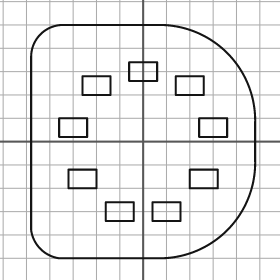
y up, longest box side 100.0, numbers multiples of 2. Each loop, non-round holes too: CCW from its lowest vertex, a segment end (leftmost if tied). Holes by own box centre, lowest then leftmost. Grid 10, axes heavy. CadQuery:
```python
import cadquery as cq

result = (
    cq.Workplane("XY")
    .moveTo(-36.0, -50.0)
    .lineTo(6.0, -50.0)
    .threePointArc((36.0, -38.0), (48.0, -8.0))
    .lineTo(48.0, 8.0)
    .threePointArc((36.0, 38.0), (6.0, 50.0))
    .lineTo(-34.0, 50.0)
    .threePointArc((-44.0, 46.0), (-48.0, 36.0))
    .lineTo(-48.0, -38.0)
    .threePointArc((-44.0, -46.0), (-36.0, -50.0))
    .close()
    .moveTo(-16.0, -34.0)
    .lineTo(-4.0, -34.0)
    .lineTo(-4.0, -26.0)
    .lineTo(-16.0, -26.0)
    .close()
    .moveTo(4.0, -34.0)
    .lineTo(16.0, -34.0)
    .lineTo(16.0, -26.0)
    .lineTo(4.0, -26.0)
    .close()
    .moveTo(-32.0, -20.0)
    .lineTo(-20.0, -20.0)
    .lineTo(-20.0, -12.0)
    .lineTo(-32.0, -12.0)
    .close()
    .moveTo(20.0, -20.0)
    .lineTo(32.0, -20.0)
    .lineTo(32.0, -12.0)
    .lineTo(20.0, -12.0)
    .close()
    .moveTo(-36.0, 2.0)
    .lineTo(-24.0, 2.0)
    .lineTo(-24.0, 10.0)
    .lineTo(-36.0, 10.0)
    .close()
    .moveTo(24.0, 2.0)
    .lineTo(36.0, 2.0)
    .lineTo(36.0, 10.0)
    .lineTo(24.0, 10.0)
    .close()
    .moveTo(-26.0, 20.0)
    .lineTo(-14.0, 20.0)
    .lineTo(-14.0, 28.0)
    .lineTo(-26.0, 28.0)
    .close()
    .moveTo(14.0, 20.0)
    .lineTo(26.0, 20.0)
    .lineTo(26.0, 28.0)
    .lineTo(14.0, 28.0)
    .close()
    .moveTo(-6.0, 26.0)
    .lineTo(6.0, 26.0)
    .lineTo(6.0, 34.0)
    .lineTo(-6.0, 34.0)
    .close()
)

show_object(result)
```